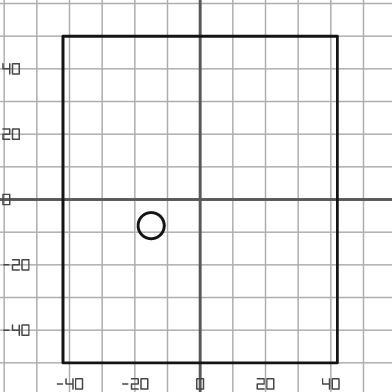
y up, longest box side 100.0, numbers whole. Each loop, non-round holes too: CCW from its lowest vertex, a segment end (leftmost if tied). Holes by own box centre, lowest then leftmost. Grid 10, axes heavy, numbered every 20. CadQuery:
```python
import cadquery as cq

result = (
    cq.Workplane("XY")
    .moveTo(-42.0, -50.0)
    .lineTo(42.0, -50.0)
    .lineTo(42.0, 50.0)
    .lineTo(-42.0, 50.0)
    .close()
    .moveTo(-15.0, -8.0)
    .circle(4.0)
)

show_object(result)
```